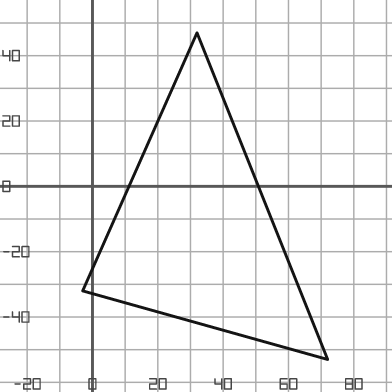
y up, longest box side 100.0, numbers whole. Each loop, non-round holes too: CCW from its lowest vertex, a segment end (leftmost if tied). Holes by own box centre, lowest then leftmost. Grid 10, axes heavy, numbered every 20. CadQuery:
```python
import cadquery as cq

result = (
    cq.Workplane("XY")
    .moveTo(72.0, -53.0)
    .lineTo(32.0, 47.0)
    .lineTo(-3.0, -32.0)
    .close()
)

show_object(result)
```